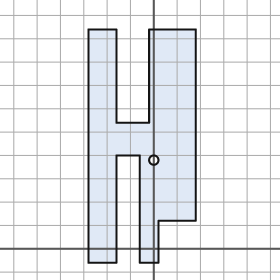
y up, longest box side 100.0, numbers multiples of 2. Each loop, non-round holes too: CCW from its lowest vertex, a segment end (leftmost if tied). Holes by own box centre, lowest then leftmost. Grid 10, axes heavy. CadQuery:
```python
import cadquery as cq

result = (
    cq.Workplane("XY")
    .moveTo(-28.0, -6.0)
    .lineTo(-16.0, -6.0)
    .lineTo(-16.0, 40.0)
    .lineTo(-6.0, 40.0)
    .lineTo(-6.0, -6.0)
    .lineTo(2.0, -6.0)
    .lineTo(2.0, 12.0)
    .lineTo(18.0, 12.0)
    .lineTo(18.0, 94.0)
    .lineTo(-2.0, 94.0)
    .lineTo(-2.0, 54.0)
    .lineTo(-16.0, 54.0)
    .lineTo(-16.0, 94.0)
    .lineTo(-28.0, 94.0)
    .close()
    .moveTo(0.0, 38.0)
    .circle(2.0)
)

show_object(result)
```